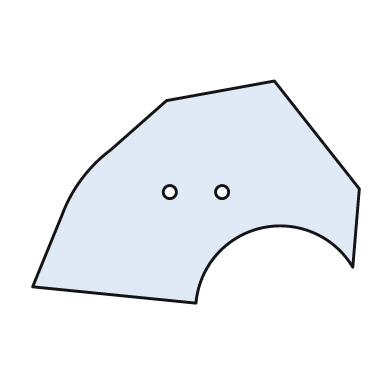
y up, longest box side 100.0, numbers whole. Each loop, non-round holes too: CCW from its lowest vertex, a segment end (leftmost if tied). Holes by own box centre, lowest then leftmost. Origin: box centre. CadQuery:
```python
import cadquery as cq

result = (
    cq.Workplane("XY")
    .moveTo(0.0, -34.0)
    .threePointArc((20.0, -11.0), (48.0, -23.0))
    .lineTo(50.0, 1.0)
    .lineTo(24.0, 34.0)
    .lineTo(-9.0, 28.0)
    .lineTo(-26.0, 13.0)
    .threePointArc((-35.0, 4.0), (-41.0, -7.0))
    .lineTo(-50.0, -29.0)
    .close()
    .moveTo(-8.0, 0.0)
    .circle(2.0)
    .moveTo(8.0, 0.0)
    .circle(2.0)
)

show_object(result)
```